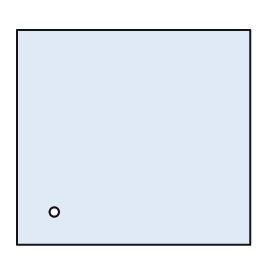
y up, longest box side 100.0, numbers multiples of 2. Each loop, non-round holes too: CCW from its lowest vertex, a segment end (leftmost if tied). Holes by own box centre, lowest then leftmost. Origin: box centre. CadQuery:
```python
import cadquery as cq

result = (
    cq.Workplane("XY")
    .moveTo(-50.0, -46.0)
    .lineTo(50.0, -46.0)
    .lineTo(50.0, 46.0)
    .lineTo(-50.0, 46.0)
    .close()
    .moveTo(-34.0, -32.0)
    .circle(2.0)
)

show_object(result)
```